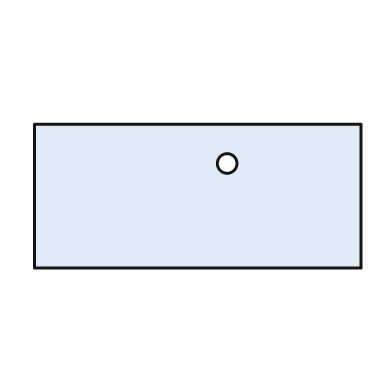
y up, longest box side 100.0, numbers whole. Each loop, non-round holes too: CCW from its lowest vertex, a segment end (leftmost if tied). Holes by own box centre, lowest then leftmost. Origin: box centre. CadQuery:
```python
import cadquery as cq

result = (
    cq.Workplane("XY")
    .moveTo(-50.0, -22.0)
    .lineTo(50.0, -22.0)
    .lineTo(50.0, 22.0)
    .lineTo(-50.0, 22.0)
    .close()
    .moveTo(9.0, 10.0)
    .circle(3.0)
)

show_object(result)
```